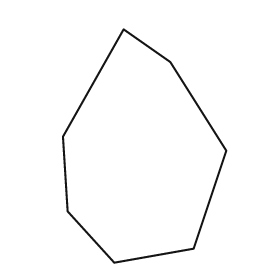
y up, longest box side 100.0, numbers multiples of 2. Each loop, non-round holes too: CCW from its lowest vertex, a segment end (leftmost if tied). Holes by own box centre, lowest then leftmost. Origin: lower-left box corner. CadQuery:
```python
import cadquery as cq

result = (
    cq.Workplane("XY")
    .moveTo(22.0, 0.0)
    .lineTo(56.0, 6.0)
    .lineTo(70.0, 48.0)
    .lineTo(46.0, 86.0)
    .lineTo(26.0, 100.0)
    .lineTo(0.0, 54.0)
    .lineTo(2.0, 22.0)
    .close()
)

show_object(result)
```